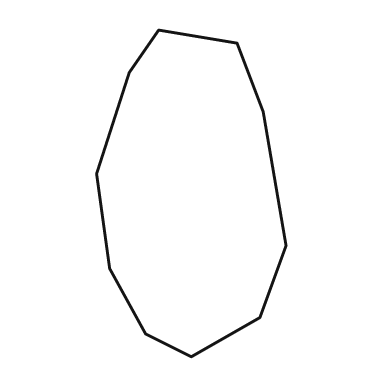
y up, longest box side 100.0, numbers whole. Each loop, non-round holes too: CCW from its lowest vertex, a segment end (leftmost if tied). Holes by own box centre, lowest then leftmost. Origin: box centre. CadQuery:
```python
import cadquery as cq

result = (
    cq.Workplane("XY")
    .moveTo(0.0, -50.0)
    .lineTo(21.0, -38.0)
    .lineTo(29.0, -16.0)
    .lineTo(22.0, 25.0)
    .lineTo(14.0, 46.0)
    .lineTo(-10.0, 50.0)
    .lineTo(-19.0, 37.0)
    .lineTo(-29.0, 6.0)
    .lineTo(-25.0, -23.0)
    .lineTo(-14.0, -43.0)
    .close()
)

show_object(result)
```